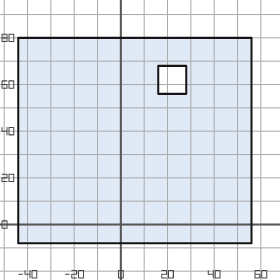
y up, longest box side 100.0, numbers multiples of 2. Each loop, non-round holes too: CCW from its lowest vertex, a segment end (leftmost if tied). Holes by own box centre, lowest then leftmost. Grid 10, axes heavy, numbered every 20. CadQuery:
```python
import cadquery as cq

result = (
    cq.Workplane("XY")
    .moveTo(-44.0, -8.0)
    .lineTo(56.0, -8.0)
    .lineTo(56.0, 80.0)
    .lineTo(-44.0, 80.0)
    .close()
    .moveTo(16.0, 56.0)
    .lineTo(28.0, 56.0)
    .lineTo(28.0, 68.0)
    .lineTo(16.0, 68.0)
    .close()
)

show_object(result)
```